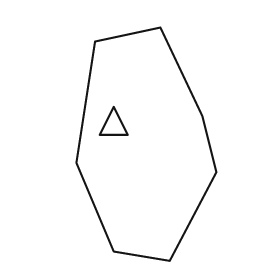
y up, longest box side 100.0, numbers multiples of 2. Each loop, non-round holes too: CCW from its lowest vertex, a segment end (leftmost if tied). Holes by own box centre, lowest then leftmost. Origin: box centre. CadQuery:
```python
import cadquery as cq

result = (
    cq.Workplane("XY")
    .moveTo(10.0, -50.0)
    .lineTo(30.0, -12.0)
    .lineTo(24.0, 12.0)
    .lineTo(6.0, 50.0)
    .lineTo(-22.0, 44.0)
    .lineTo(-30.0, -8.0)
    .lineTo(-14.0, -46.0)
    .close()
    .moveTo(-20.0, 4.0)
    .lineTo(-8.0, 4.0)
    .lineTo(-14.0, 16.0)
    .close()
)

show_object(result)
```